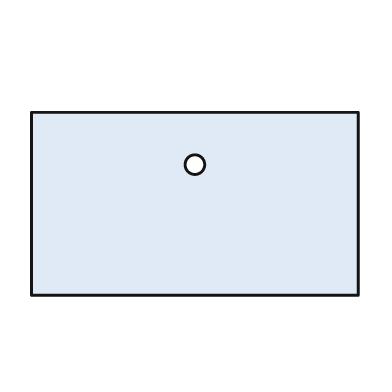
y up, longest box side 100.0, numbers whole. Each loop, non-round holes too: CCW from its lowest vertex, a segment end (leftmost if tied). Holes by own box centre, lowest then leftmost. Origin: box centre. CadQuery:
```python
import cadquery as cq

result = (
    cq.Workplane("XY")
    .moveTo(-50.0, -28.0)
    .lineTo(50.0, -28.0)
    .lineTo(50.0, 28.0)
    .lineTo(-50.0, 28.0)
    .close()
    .moveTo(0.0, 12.0)
    .circle(3.0)
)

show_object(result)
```